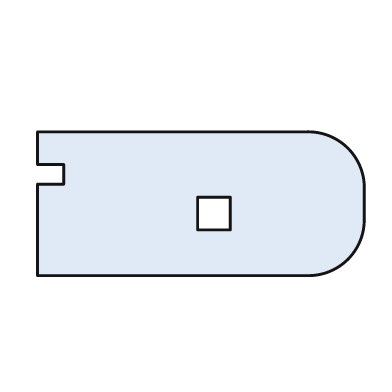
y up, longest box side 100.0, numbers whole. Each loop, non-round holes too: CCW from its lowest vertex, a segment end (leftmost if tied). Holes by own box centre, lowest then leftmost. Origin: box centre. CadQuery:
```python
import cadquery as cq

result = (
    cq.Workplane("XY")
    .moveTo(-50.0, -22.0)
    .lineTo(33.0, -22.0)
    .threePointArc((45.0, -17.0), (50.0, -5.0))
    .lineTo(50.0, 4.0)
    .threePointArc((45.0, 17.0), (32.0, 22.0))
    .lineTo(-50.0, 22.0)
    .lineTo(-50.0, 12.0)
    .lineTo(-42.0, 12.0)
    .lineTo(-42.0, 6.0)
    .lineTo(-50.0, 6.0)
    .close()
    .moveTo(-1.0, -8.0)
    .lineTo(9.0, -8.0)
    .lineTo(9.0, 2.0)
    .lineTo(-1.0, 2.0)
    .close()
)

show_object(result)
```